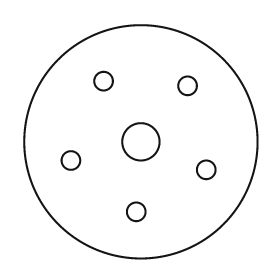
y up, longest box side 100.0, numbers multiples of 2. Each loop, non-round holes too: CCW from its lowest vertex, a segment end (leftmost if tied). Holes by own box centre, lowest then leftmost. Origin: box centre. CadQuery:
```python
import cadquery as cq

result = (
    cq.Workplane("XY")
    .moveTo(0.0, 0.0)
    .circle(50.0)
    .moveTo(-2.0, -30.0)
    .circle(4.0)
    .moveTo(28.0, -12.0)
    .circle(4.0)
    .moveTo(-30.0, -8.0)
    .circle(4.0)
    .moveTo(0.0, 0.0)
    .circle(8.0)
    .moveTo(20.0, 24.0)
    .circle(4.0)
    .moveTo(-16.0, 26.0)
    .circle(4.0)
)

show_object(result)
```